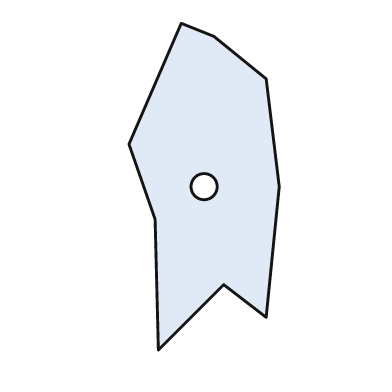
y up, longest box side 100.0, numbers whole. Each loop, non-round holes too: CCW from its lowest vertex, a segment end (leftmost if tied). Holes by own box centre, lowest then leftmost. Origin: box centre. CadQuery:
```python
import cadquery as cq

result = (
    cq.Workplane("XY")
    .moveTo(-14.0, -50.0)
    .lineTo(6.0, -30.0)
    .lineTo(19.0, -40.0)
    .lineTo(23.0, 0.0)
    .lineTo(19.0, 33.0)
    .lineTo(3.0, 46.0)
    .lineTo(-7.0, 50.0)
    .lineTo(-23.0, 13.0)
    .lineTo(-15.0, -10.0)
    .close()
    .moveTo(0.0, 0.0)
    .circle(4.0)
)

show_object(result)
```